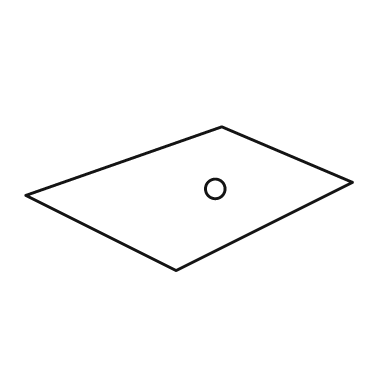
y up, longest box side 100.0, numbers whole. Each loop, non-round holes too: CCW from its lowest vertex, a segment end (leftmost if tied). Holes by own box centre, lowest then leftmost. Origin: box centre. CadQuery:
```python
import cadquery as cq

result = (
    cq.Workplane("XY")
    .moveTo(-4.0, -22.0)
    .lineTo(50.0, 5.0)
    .lineTo(10.0, 22.0)
    .lineTo(-50.0, 1.0)
    .close()
    .moveTo(8.0, 3.0)
    .circle(3.0)
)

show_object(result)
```